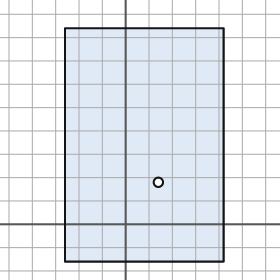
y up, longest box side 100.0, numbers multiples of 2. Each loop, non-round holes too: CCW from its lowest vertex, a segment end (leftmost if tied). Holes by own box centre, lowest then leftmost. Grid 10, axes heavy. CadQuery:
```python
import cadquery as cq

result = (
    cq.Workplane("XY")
    .moveTo(-26.0, -16.0)
    .lineTo(42.0, -16.0)
    .lineTo(42.0, 84.0)
    .lineTo(-26.0, 84.0)
    .close()
    .moveTo(14.0, 18.0)
    .circle(2.0)
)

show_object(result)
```